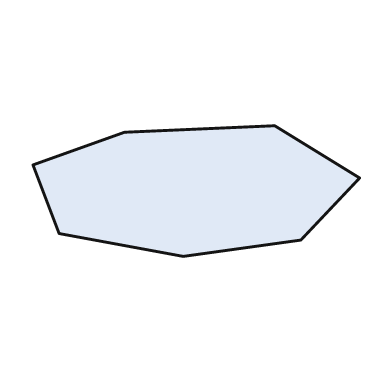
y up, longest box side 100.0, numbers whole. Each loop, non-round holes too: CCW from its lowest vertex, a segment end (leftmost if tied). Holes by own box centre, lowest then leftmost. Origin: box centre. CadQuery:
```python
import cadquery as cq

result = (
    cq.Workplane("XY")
    .moveTo(-4.0, -20.0)
    .lineTo(32.0, -15.0)
    .lineTo(50.0, 4.0)
    .lineTo(24.0, 20.0)
    .lineTo(-22.0, 18.0)
    .lineTo(-50.0, 8.0)
    .lineTo(-42.0, -13.0)
    .close()
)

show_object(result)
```